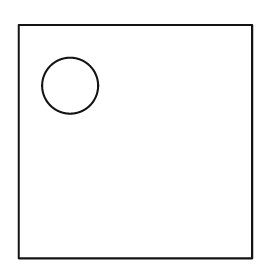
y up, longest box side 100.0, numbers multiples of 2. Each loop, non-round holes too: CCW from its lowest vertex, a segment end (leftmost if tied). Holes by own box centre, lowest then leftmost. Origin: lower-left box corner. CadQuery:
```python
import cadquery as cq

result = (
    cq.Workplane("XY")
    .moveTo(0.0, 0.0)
    .lineTo(100.0, 0.0)
    .lineTo(100.0, 100.0)
    .lineTo(0.0, 100.0)
    .close()
    .moveTo(22.0, 74.0)
    .circle(12.0)
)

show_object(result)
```